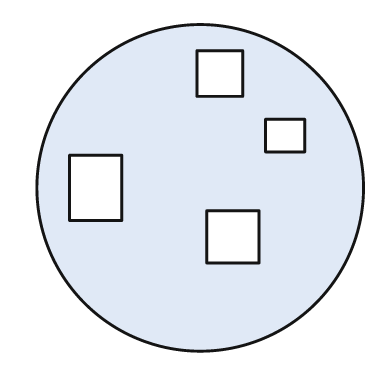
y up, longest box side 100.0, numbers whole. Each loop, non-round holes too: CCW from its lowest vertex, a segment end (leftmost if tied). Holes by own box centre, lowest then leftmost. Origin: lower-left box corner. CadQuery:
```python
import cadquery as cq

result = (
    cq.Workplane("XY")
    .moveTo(50.0, 50.0)
    .circle(50.0)
    .moveTo(52.0, 27.0)
    .lineTo(68.0, 27.0)
    .lineTo(68.0, 43.0)
    .lineTo(52.0, 43.0)
    .close()
    .moveTo(10.0, 40.0)
    .lineTo(26.0, 40.0)
    .lineTo(26.0, 60.0)
    .lineTo(10.0, 60.0)
    .close()
    .moveTo(70.0, 61.0)
    .lineTo(82.0, 61.0)
    .lineTo(82.0, 71.0)
    .lineTo(70.0, 71.0)
    .close()
    .moveTo(49.0, 78.0)
    .lineTo(63.0, 78.0)
    .lineTo(63.0, 92.0)
    .lineTo(49.0, 92.0)
    .close()
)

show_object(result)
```